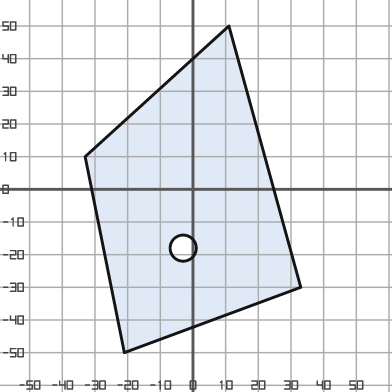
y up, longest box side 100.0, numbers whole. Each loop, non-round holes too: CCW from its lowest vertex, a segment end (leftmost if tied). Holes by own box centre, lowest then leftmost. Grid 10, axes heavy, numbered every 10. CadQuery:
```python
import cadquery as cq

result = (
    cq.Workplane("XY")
    .moveTo(-21.0, -50.0)
    .lineTo(33.0, -30.0)
    .lineTo(11.0, 50.0)
    .lineTo(-33.0, 10.0)
    .close()
    .moveTo(-3.0, -18.0)
    .circle(4.0)
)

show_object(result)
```